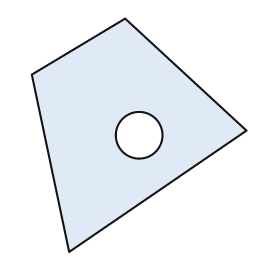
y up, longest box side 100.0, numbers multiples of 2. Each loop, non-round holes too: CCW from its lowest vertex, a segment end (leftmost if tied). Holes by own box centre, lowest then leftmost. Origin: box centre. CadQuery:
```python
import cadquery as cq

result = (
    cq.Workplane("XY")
    .moveTo(-30.0, -50.0)
    .lineTo(46.0, 2.0)
    .lineTo(-6.0, 50.0)
    .lineTo(-46.0, 26.0)
    .close()
    .moveTo(0.0, 0.0)
    .circle(10.0)
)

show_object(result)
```